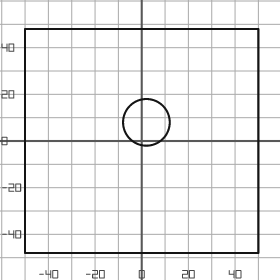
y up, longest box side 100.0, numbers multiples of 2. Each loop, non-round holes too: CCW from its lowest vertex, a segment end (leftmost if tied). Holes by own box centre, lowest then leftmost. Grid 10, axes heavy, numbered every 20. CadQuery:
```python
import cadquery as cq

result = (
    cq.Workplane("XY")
    .moveTo(-50.0, -48.0)
    .lineTo(50.0, -48.0)
    .lineTo(50.0, 48.0)
    .lineTo(-50.0, 48.0)
    .close()
    .moveTo(2.0, 8.0)
    .circle(10.0)
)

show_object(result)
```